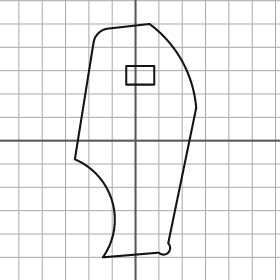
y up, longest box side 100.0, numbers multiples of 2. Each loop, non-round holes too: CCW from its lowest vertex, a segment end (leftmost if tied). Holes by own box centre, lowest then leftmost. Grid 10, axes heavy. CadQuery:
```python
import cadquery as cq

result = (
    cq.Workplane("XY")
    .moveTo(-14.0, -50.0)
    .lineTo(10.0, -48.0)
    .threePointArc((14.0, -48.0), (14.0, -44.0))
    .lineTo(26.0, 14.0)
    .threePointArc((20.0, 34.0), (6.0, 50.0))
    .lineTo(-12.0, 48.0)
    .threePointArc((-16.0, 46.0), (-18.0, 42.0))
    .lineTo(-26.0, -8.0)
    .threePointArc((-10.0, -26.0), (-14.0, -50.0))
    .close()
    .moveTo(-4.0, 24.0)
    .lineTo(8.0, 24.0)
    .lineTo(8.0, 32.0)
    .lineTo(-4.0, 32.0)
    .close()
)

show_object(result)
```